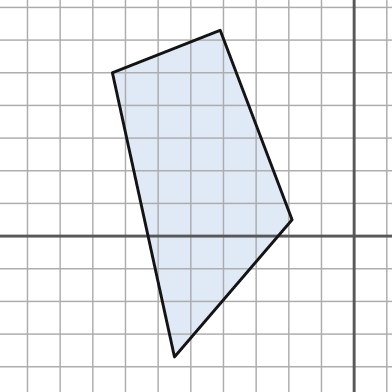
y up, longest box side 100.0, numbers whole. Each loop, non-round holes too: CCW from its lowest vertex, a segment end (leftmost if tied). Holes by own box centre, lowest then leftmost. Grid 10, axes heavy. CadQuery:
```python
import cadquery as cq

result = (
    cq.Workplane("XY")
    .moveTo(-55.0, -37.0)
    .lineTo(-19.0, 5.0)
    .lineTo(-41.0, 63.0)
    .lineTo(-74.0, 50.0)
    .close()
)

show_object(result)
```